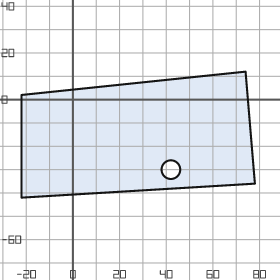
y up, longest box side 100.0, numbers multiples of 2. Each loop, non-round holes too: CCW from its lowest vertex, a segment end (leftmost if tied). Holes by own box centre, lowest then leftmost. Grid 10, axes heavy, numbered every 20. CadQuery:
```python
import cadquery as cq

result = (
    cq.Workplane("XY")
    .moveTo(-22.0, -42.0)
    .lineTo(78.0, -36.0)
    .lineTo(74.0, 12.0)
    .lineTo(-22.0, 2.0)
    .close()
    .moveTo(42.0, -30.0)
    .circle(4.0)
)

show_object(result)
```